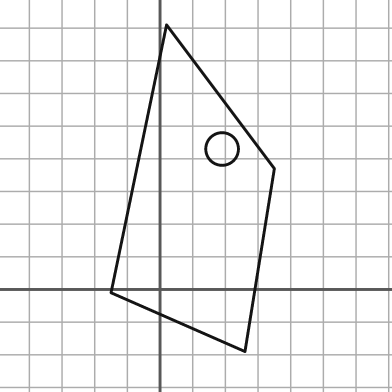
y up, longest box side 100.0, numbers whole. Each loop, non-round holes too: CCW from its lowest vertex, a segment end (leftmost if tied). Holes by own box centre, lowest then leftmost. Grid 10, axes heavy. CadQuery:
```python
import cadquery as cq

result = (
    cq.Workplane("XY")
    .moveTo(26.0, -19.0)
    .lineTo(35.0, 37.0)
    .lineTo(2.0, 81.0)
    .lineTo(-15.0, -1.0)
    .close()
    .moveTo(19.0, 43.0)
    .circle(5.0)
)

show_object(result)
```